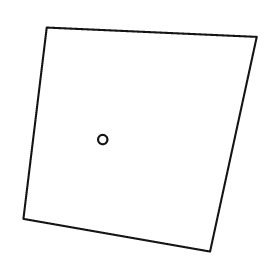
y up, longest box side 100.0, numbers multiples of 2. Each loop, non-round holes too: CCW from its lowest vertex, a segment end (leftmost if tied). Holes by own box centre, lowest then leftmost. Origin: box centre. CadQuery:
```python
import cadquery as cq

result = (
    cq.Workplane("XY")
    .moveTo(30.0, -48.0)
    .lineTo(50.0, 44.0)
    .lineTo(-40.0, 48.0)
    .lineTo(-50.0, -34.0)
    .close()
    .moveTo(-16.0, 0.0)
    .circle(2.0)
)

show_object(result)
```